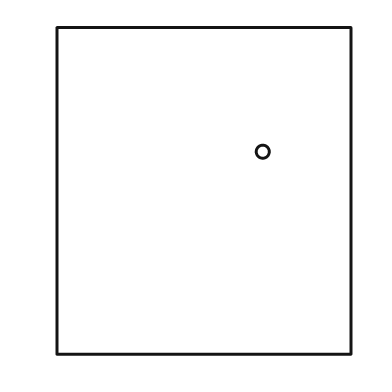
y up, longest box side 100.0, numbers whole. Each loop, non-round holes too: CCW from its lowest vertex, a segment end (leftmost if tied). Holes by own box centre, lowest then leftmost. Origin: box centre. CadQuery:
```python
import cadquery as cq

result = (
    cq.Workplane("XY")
    .moveTo(-45.0, -50.0)
    .lineTo(45.0, -50.0)
    .lineTo(45.0, 50.0)
    .lineTo(-45.0, 50.0)
    .close()
    .moveTo(18.0, 12.0)
    .circle(2.0)
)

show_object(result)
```